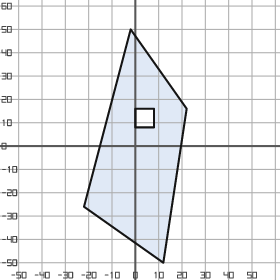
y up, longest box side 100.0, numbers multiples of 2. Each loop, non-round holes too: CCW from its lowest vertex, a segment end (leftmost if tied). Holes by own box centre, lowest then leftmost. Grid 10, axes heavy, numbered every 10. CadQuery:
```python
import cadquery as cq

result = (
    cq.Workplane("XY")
    .moveTo(12.0, -50.0)
    .lineTo(22.0, 16.0)
    .lineTo(-2.0, 50.0)
    .lineTo(-22.0, -26.0)
    .close()
    .moveTo(0.0, 8.0)
    .lineTo(8.0, 8.0)
    .lineTo(8.0, 16.0)
    .lineTo(0.0, 16.0)
    .close()
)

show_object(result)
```